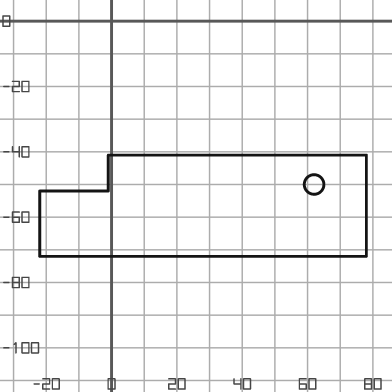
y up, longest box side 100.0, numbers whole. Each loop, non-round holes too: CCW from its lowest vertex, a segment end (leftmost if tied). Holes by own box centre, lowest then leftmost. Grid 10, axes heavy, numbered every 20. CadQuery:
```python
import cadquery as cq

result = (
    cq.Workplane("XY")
    .moveTo(-22.0, -72.0)
    .lineTo(78.0, -72.0)
    .lineTo(78.0, -41.0)
    .lineTo(-1.0, -41.0)
    .lineTo(-1.0, -52.0)
    .lineTo(-22.0, -52.0)
    .close()
    .moveTo(62.0, -50.0)
    .circle(3.0)
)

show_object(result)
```